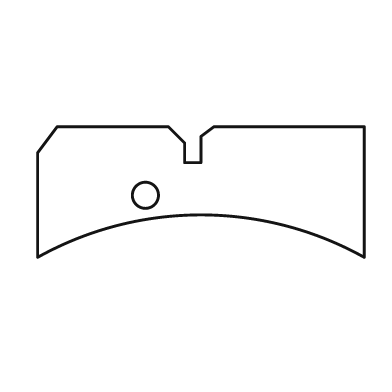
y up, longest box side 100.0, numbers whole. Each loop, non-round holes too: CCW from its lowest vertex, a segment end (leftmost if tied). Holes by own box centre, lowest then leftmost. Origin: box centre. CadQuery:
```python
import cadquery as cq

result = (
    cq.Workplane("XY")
    .moveTo(-50.0, -20.0)
    .threePointArc((0.0, -7.0), (50.0, -20.0))
    .lineTo(50.0, 20.0)
    .lineTo(4.0, 20.0)
    .lineTo(0.0, 17.0)
    .lineTo(0.0, 9.0)
    .lineTo(-5.0, 9.0)
    .lineTo(-5.0, 15.0)
    .lineTo(-10.0, 20.0)
    .lineTo(-44.0, 20.0)
    .lineTo(-50.0, 12.0)
    .close()
    .moveTo(-17.0, -1.0)
    .circle(4.0)
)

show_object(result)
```